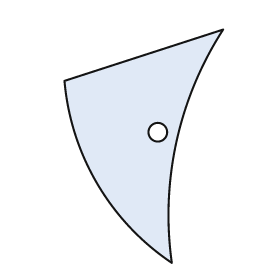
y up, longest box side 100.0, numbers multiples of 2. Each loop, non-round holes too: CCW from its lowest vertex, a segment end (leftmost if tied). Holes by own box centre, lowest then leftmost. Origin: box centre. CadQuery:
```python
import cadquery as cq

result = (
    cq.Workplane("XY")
    .moveTo(12.0, -50.0)
    .threePointArc((14.0, 2.0), (34.0, 50.0))
    .lineTo(-34.0, 28.0)
    .threePointArc((-20.0, -16.0), (12.0, -50.0))
    .close()
    .moveTo(6.0, 6.0)
    .circle(4.0)
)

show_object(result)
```